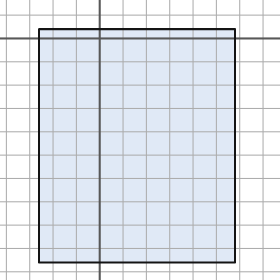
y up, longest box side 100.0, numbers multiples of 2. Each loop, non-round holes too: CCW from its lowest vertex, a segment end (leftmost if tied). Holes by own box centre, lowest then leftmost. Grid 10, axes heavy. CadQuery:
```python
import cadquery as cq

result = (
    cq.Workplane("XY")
    .moveTo(-26.0, -96.0)
    .lineTo(58.0, -96.0)
    .lineTo(58.0, 4.0)
    .lineTo(-26.0, 4.0)
    .close()
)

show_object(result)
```